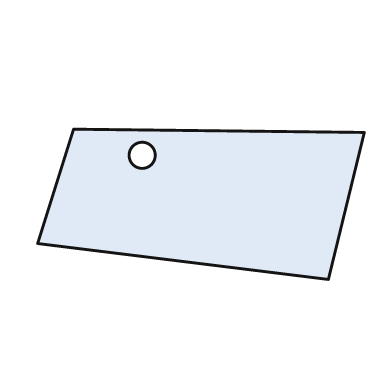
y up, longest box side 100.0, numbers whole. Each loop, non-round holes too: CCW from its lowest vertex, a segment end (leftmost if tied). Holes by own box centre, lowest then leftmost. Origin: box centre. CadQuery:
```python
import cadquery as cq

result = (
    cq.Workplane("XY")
    .moveTo(39.0, -23.0)
    .lineTo(50.0, 22.0)
    .lineTo(-39.0, 23.0)
    .lineTo(-50.0, -12.0)
    .close()
    .moveTo(-18.0, 15.0)
    .circle(4.0)
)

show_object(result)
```